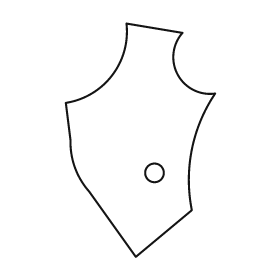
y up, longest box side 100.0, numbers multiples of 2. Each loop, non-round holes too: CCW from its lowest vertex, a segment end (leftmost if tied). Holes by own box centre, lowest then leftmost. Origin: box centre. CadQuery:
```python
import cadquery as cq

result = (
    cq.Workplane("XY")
    .moveTo(-2.0, -50.0)
    .lineTo(22.0, -30.0)
    .threePointArc((22.0, -4.0), (32.0, 20.0))
    .threePointArc((16.0, 28.0), (18.0, 46.0))
    .lineTo(-6.0, 50.0)
    .threePointArc((-12.0, 28.0), (-32.0, 16.0))
    .lineTo(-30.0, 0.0)
    .threePointArc((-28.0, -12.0), (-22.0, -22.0))
    .close()
    .moveTo(6.0, -14.0)
    .circle(4.0)
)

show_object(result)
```